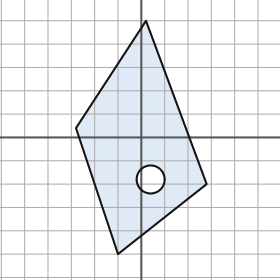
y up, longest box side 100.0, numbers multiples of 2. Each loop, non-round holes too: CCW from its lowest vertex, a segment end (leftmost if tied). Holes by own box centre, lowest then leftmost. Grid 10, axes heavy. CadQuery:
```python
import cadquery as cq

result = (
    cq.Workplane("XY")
    .moveTo(-10.0, -50.0)
    .lineTo(28.0, -20.0)
    .lineTo(2.0, 50.0)
    .lineTo(-28.0, 4.0)
    .close()
    .moveTo(4.0, -18.0)
    .circle(6.0)
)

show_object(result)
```